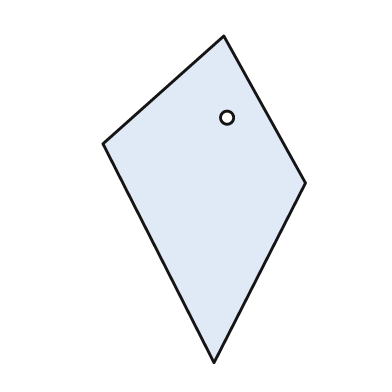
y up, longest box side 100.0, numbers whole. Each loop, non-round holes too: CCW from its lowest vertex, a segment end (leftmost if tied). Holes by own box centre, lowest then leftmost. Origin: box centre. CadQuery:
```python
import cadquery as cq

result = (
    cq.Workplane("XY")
    .moveTo(3.0, -50.0)
    .lineTo(31.0, 5.0)
    .lineTo(6.0, 50.0)
    .lineTo(-31.0, 17.0)
    .close()
    .moveTo(7.0, 25.0)
    .circle(2.0)
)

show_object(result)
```